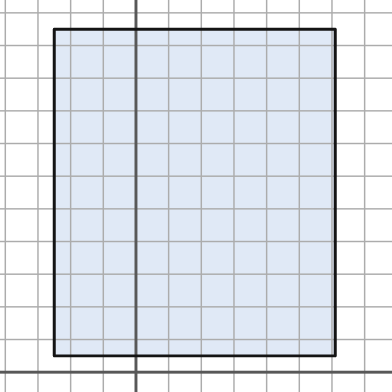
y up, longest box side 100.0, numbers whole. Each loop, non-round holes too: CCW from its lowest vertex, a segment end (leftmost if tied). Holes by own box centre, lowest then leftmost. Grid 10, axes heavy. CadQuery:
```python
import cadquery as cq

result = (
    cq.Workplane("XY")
    .moveTo(-25.0, 5.0)
    .lineTo(61.0, 5.0)
    .lineTo(61.0, 105.0)
    .lineTo(-25.0, 105.0)
    .close()
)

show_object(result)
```